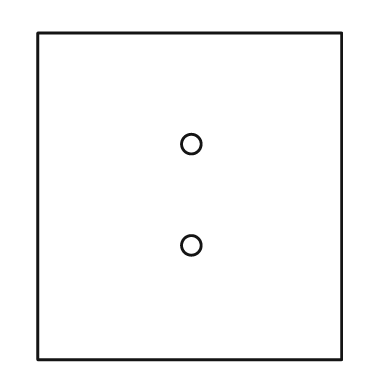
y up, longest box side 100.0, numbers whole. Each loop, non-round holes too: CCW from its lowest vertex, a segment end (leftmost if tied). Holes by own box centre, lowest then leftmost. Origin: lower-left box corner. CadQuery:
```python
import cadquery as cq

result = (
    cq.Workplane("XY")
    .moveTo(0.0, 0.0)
    .lineTo(93.0, 0.0)
    .lineTo(93.0, 100.0)
    .lineTo(0.0, 100.0)
    .close()
    .moveTo(47.0, 35.0)
    .circle(3.0)
    .moveTo(47.0, 66.0)
    .circle(3.0)
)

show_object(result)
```